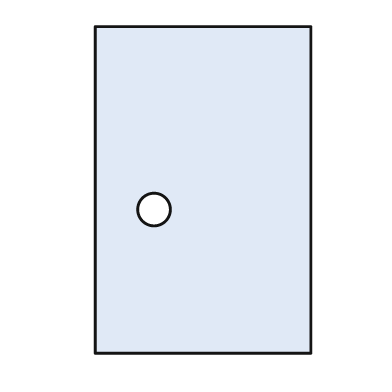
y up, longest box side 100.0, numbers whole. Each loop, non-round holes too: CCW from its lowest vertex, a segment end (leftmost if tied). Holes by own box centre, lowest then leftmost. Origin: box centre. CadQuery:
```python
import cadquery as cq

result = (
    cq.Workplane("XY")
    .moveTo(-33.0, -50.0)
    .lineTo(33.0, -50.0)
    .lineTo(33.0, 50.0)
    .lineTo(-33.0, 50.0)
    .close()
    .moveTo(-15.0, -6.0)
    .circle(5.0)
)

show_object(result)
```